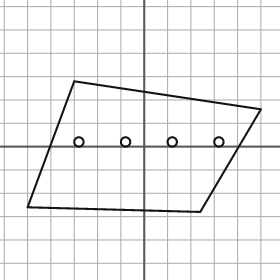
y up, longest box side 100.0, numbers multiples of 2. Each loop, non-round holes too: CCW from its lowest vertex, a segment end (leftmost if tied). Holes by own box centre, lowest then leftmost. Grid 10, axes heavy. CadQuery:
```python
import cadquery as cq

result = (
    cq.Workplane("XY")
    .moveTo(24.0, -28.0)
    .lineTo(50.0, 16.0)
    .lineTo(-30.0, 28.0)
    .lineTo(-50.0, -26.0)
    .close()
    .moveTo(-28.0, 2.0)
    .circle(2.0)
    .moveTo(-8.0, 2.0)
    .circle(2.0)
    .moveTo(12.0, 2.0)
    .circle(2.0)
    .moveTo(32.0, 2.0)
    .circle(2.0)
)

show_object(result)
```